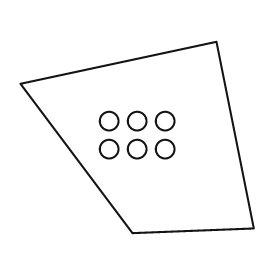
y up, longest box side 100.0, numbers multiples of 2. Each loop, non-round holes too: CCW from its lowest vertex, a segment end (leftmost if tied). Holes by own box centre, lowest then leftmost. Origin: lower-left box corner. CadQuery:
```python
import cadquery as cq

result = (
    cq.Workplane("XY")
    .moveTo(48.0, 0.0)
    .lineTo(100.0, 2.0)
    .lineTo(84.0, 82.0)
    .lineTo(0.0, 64.0)
    .close()
    .moveTo(38.0, 36.0)
    .circle(4.0)
    .moveTo(50.0, 36.0)
    .circle(4.0)
    .moveTo(62.0, 36.0)
    .circle(4.0)
    .moveTo(38.0, 48.0)
    .circle(4.0)
    .moveTo(50.0, 48.0)
    .circle(4.0)
    .moveTo(62.0, 48.0)
    .circle(4.0)
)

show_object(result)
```